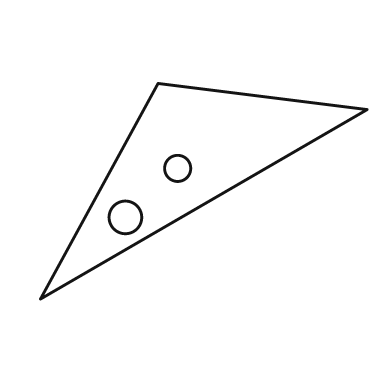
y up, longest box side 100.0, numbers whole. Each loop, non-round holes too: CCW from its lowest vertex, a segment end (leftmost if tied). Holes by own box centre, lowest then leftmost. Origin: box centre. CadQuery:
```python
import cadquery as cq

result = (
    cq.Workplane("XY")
    .moveTo(-50.0, -33.0)
    .lineTo(50.0, 25.0)
    .lineTo(-14.0, 33.0)
    .close()
    .moveTo(-24.0, -8.0)
    .circle(5.0)
    .moveTo(-8.0, 7.0)
    .circle(4.0)
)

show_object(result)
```